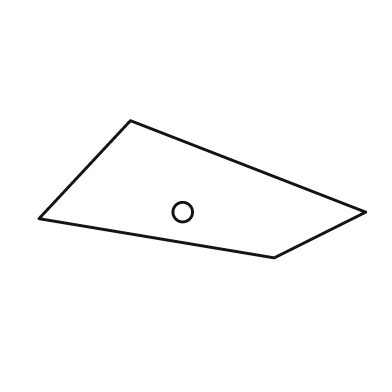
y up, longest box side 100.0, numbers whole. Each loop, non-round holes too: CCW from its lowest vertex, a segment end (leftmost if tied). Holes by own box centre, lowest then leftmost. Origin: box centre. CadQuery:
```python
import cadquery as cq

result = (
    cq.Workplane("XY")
    .moveTo(22.0, -21.0)
    .lineTo(50.0, -7.0)
    .lineTo(-22.0, 21.0)
    .lineTo(-50.0, -9.0)
    .close()
    .moveTo(-6.0, -7.0)
    .circle(3.0)
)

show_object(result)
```